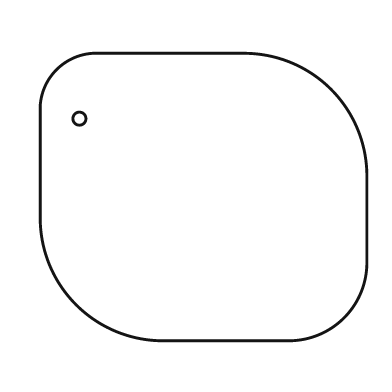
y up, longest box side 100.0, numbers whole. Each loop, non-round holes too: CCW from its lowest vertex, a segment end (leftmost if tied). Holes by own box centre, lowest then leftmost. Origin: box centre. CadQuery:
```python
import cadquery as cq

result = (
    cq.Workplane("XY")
    .moveTo(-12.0, -44.0)
    .lineTo(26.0, -44.0)
    .threePointArc((43.0, -37.0), (50.0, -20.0))
    .lineTo(50.0, 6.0)
    .threePointArc((39.0, 33.0), (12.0, 44.0))
    .lineTo(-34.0, 44.0)
    .threePointArc((-45.0, 39.0), (-50.0, 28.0))
    .lineTo(-50.0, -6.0)
    .threePointArc((-39.0, -33.0), (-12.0, -44.0))
    .close()
    .moveTo(-38.0, 24.0)
    .circle(2.0)
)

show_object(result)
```